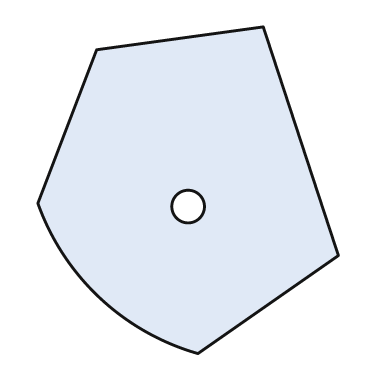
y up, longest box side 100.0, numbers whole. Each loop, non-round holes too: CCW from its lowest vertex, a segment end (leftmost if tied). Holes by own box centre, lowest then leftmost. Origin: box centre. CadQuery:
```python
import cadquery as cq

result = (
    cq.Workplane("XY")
    .moveTo(3.0, -50.0)
    .lineTo(46.0, -20.0)
    .lineTo(23.0, 50.0)
    .lineTo(-28.0, 43.0)
    .lineTo(-46.0, -4.0)
    .threePointArc((-27.0, -33.0), (3.0, -50.0))
    .close()
    .moveTo(0.0, -5.0)
    .circle(5.0)
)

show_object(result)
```